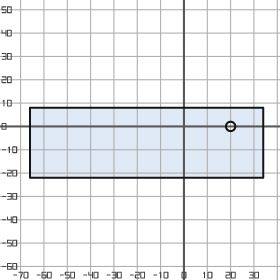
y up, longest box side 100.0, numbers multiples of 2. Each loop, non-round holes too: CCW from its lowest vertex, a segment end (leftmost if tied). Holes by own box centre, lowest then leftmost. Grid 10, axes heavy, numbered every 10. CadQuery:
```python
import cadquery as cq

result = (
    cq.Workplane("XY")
    .moveTo(-66.0, -22.0)
    .lineTo(34.0, -22.0)
    .lineTo(34.0, 8.0)
    .lineTo(-66.0, 8.0)
    .close()
    .moveTo(20.0, 0.0)
    .circle(2.0)
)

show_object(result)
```